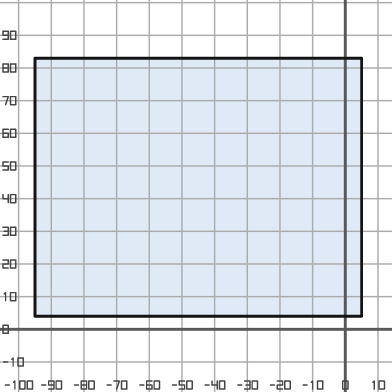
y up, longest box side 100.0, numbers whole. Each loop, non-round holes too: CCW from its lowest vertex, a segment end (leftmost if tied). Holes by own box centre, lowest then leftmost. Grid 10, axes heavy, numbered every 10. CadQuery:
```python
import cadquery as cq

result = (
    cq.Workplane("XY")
    .moveTo(-95.0, 4.0)
    .lineTo(5.0, 4.0)
    .lineTo(5.0, 83.0)
    .lineTo(-95.0, 83.0)
    .close()
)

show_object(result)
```